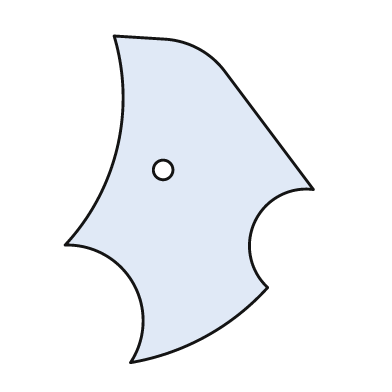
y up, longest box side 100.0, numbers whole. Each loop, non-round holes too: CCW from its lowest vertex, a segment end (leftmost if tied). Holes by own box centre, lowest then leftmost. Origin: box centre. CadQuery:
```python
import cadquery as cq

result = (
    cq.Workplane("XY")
    .moveTo(-18.0, -50.0)
    .threePointArc((5.0, -42.0), (24.0, -27.0))
    .threePointArc((20.0, -7.0), (38.0, 3.0))
    .lineTo(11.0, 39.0)
    .threePointArc((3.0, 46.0), (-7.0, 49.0))
    .lineTo(-23.0, 50.0)
    .threePointArc((-22.0, 16.0), (-38.0, -14.0))
    .threePointArc((-17.0, -26.0), (-18.0, -50.0))
    .close()
    .moveTo(-8.0, 9.0)
    .circle(3.0)
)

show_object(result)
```